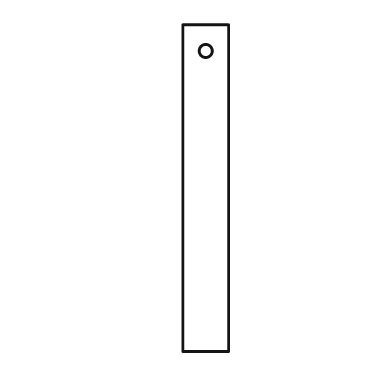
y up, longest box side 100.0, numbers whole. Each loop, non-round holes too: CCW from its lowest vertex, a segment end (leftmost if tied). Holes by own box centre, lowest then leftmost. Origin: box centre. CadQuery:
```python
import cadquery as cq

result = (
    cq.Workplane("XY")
    .moveTo(-7.0, -50.0)
    .lineTo(7.0, -50.0)
    .lineTo(7.0, 50.0)
    .lineTo(-7.0, 50.0)
    .close()
    .moveTo(0.0, 42.0)
    .circle(2.0)
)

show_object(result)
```